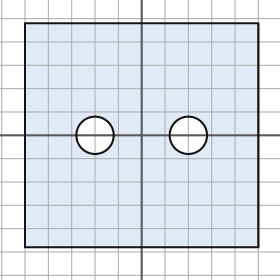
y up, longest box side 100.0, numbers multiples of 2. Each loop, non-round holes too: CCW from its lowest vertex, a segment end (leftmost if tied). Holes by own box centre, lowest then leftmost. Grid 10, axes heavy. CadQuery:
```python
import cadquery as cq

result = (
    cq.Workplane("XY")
    .moveTo(-50.0, -48.0)
    .lineTo(50.0, -48.0)
    .lineTo(50.0, 48.0)
    .lineTo(-50.0, 48.0)
    .close()
    .moveTo(-20.0, 0.0)
    .circle(8.0)
    .moveTo(20.0, 0.0)
    .circle(8.0)
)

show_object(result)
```